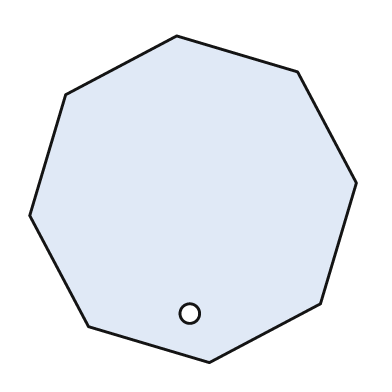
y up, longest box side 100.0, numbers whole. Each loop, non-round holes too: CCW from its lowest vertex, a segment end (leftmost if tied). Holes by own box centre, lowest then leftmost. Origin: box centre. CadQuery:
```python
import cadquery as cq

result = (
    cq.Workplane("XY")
    .moveTo(5.0, -50.0)
    .lineTo(39.0, -32.0)
    .lineTo(50.0, 5.0)
    .lineTo(32.0, 39.0)
    .lineTo(-5.0, 50.0)
    .lineTo(-39.0, 32.0)
    .lineTo(-50.0, -5.0)
    .lineTo(-32.0, -39.0)
    .close()
    .moveTo(-1.0, -35.0)
    .circle(3.0)
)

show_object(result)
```